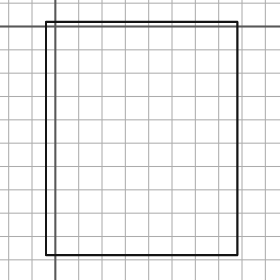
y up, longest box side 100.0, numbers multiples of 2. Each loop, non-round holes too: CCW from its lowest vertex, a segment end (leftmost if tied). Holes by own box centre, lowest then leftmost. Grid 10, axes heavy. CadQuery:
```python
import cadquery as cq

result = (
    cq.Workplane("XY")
    .moveTo(-4.0, -98.0)
    .lineTo(78.0, -98.0)
    .lineTo(78.0, 2.0)
    .lineTo(-4.0, 2.0)
    .close()
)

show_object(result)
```